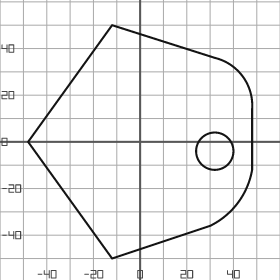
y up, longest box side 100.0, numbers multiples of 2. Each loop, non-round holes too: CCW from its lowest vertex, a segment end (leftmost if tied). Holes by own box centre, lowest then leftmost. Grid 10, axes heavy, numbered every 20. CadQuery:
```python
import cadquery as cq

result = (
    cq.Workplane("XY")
    .moveTo(-12.0, -50.0)
    .lineTo(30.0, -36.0)
    .threePointArc((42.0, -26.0), (48.0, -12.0))
    .lineTo(48.0, 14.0)
    .threePointArc((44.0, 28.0), (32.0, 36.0))
    .lineTo(-12.0, 50.0)
    .lineTo(-48.0, 0.0)
    .close()
    .moveTo(32.0, -4.0)
    .circle(8.0)
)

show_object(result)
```